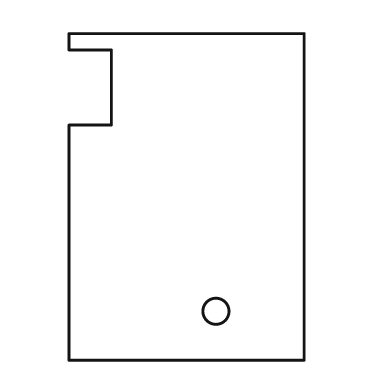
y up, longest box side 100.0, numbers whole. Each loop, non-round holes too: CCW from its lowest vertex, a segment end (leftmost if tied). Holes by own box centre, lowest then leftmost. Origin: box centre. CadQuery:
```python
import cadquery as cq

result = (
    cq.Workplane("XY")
    .moveTo(-36.0, -50.0)
    .lineTo(36.0, -50.0)
    .lineTo(36.0, 50.0)
    .lineTo(-36.0, 50.0)
    .lineTo(-36.0, 45.0)
    .lineTo(-23.0, 45.0)
    .lineTo(-23.0, 22.0)
    .lineTo(-36.0, 22.0)
    .close()
    .moveTo(9.0, -35.0)
    .circle(4.0)
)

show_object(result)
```